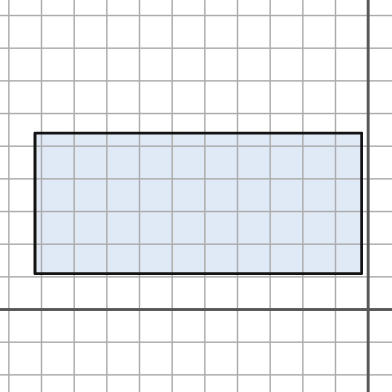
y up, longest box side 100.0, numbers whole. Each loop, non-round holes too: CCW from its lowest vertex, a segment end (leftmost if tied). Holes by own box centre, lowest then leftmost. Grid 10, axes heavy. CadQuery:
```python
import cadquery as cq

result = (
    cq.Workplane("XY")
    .moveTo(-102.0, 11.0)
    .lineTo(-2.0, 11.0)
    .lineTo(-2.0, 54.0)
    .lineTo(-102.0, 54.0)
    .close()
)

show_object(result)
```